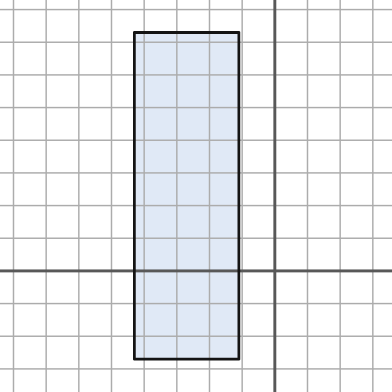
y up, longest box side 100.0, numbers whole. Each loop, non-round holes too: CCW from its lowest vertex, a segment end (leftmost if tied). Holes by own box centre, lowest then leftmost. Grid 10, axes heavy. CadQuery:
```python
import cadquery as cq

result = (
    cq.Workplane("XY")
    .moveTo(-43.0, -27.0)
    .lineTo(-11.0, -27.0)
    .lineTo(-11.0, 73.0)
    .lineTo(-43.0, 73.0)
    .close()
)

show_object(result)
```